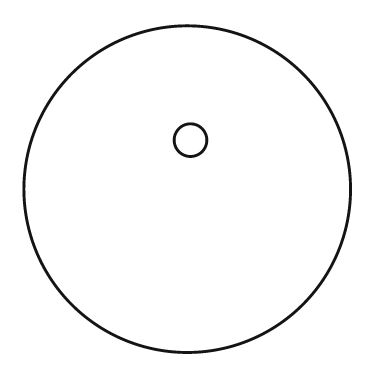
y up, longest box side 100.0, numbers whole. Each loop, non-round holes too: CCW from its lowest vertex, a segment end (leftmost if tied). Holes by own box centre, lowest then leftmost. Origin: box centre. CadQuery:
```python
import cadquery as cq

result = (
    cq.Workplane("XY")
    .moveTo(0.0, 0.0)
    .circle(50.0)
    .moveTo(1.0, 15.0)
    .circle(5.0)
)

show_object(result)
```